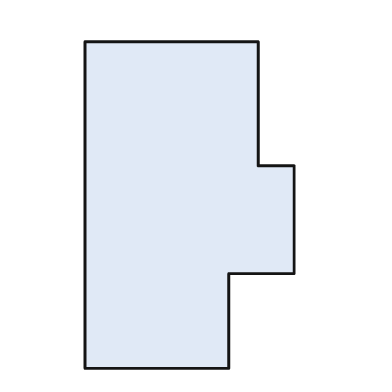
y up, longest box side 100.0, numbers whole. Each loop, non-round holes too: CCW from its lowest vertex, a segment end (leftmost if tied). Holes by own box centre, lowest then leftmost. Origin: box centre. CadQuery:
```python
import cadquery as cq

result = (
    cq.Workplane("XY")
    .moveTo(-32.0, -50.0)
    .lineTo(12.0, -50.0)
    .lineTo(12.0, -21.0)
    .lineTo(32.0, -21.0)
    .lineTo(32.0, 12.0)
    .lineTo(21.0, 12.0)
    .lineTo(21.0, 50.0)
    .lineTo(-32.0, 50.0)
    .close()
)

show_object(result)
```